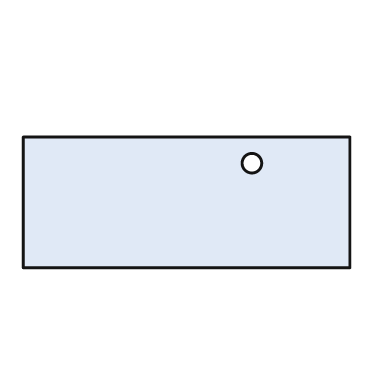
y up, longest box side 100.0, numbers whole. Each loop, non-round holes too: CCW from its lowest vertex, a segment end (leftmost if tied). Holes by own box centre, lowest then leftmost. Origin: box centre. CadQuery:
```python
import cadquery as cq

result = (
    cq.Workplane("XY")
    .moveTo(-50.0, -20.0)
    .lineTo(50.0, -20.0)
    .lineTo(50.0, 20.0)
    .lineTo(-50.0, 20.0)
    .close()
    .moveTo(20.0, 12.0)
    .circle(3.0)
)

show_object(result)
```